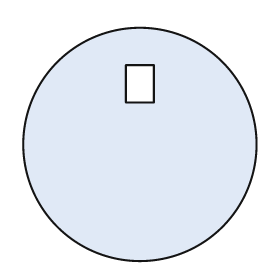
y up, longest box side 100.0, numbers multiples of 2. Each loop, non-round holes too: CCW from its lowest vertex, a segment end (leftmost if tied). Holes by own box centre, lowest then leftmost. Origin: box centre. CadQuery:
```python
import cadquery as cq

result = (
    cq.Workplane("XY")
    .moveTo(0.0, 0.0)
    .circle(50.0)
    .moveTo(-6.0, 18.0)
    .lineTo(6.0, 18.0)
    .lineTo(6.0, 34.0)
    .lineTo(-6.0, 34.0)
    .close()
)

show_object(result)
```